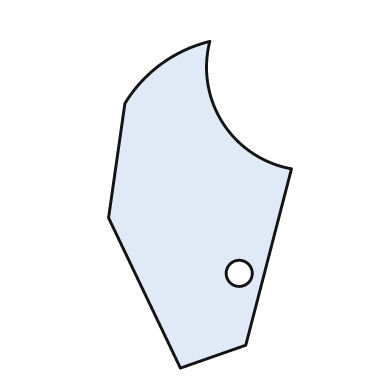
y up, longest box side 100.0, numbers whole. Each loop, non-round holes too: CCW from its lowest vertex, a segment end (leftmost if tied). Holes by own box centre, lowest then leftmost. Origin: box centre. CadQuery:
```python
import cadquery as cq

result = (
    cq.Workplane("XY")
    .moveTo(-6.0, -50.0)
    .lineTo(14.0, -43.0)
    .lineTo(28.0, 11.0)
    .threePointArc((7.0, 25.0), (3.0, 50.0))
    .threePointArc((-12.0, 43.0), (-23.0, 31.0))
    .lineTo(-28.0, -4.0)
    .close()
    .moveTo(12.0, -21.0)
    .circle(4.0)
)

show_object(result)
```